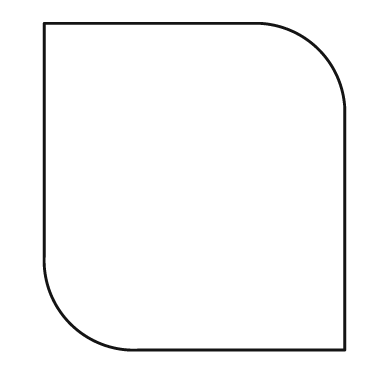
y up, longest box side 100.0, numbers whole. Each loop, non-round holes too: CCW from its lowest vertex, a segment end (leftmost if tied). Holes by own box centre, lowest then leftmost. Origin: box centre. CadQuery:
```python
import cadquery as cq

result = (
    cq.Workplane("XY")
    .moveTo(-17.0, -50.0)
    .lineTo(46.0, -50.0)
    .lineTo(46.0, 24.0)
    .threePointArc((38.0, 42.0), (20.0, 50.0))
    .lineTo(-46.0, 50.0)
    .lineTo(-46.0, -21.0)
    .threePointArc((-38.0, -42.0), (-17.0, -50.0))
    .close()
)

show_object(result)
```